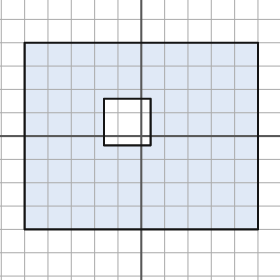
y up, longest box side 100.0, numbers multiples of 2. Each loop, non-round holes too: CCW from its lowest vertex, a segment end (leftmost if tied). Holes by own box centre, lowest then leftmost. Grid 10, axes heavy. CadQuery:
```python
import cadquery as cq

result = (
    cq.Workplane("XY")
    .moveTo(-50.0, -40.0)
    .lineTo(50.0, -40.0)
    .lineTo(50.0, 40.0)
    .lineTo(-50.0, 40.0)
    .close()
    .moveTo(-16.0, -4.0)
    .lineTo(4.0, -4.0)
    .lineTo(4.0, 16.0)
    .lineTo(-16.0, 16.0)
    .close()
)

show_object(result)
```